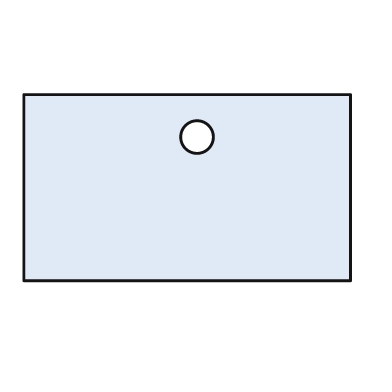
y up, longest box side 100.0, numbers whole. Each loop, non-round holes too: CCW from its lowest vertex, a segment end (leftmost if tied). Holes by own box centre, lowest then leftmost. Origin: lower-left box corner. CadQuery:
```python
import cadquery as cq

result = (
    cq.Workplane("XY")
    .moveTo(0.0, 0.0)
    .lineTo(100.0, 0.0)
    .lineTo(100.0, 57.0)
    .lineTo(0.0, 57.0)
    .close()
    .moveTo(53.0, 44.0)
    .circle(5.0)
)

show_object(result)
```